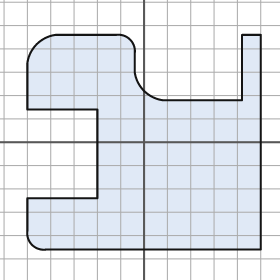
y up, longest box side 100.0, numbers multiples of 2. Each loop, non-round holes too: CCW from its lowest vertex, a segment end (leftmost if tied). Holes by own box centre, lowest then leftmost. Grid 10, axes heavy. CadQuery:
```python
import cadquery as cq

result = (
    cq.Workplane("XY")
    .moveTo(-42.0, -46.0)
    .lineTo(50.0, -46.0)
    .lineTo(50.0, 46.0)
    .lineTo(42.0, 46.0)
    .lineTo(42.0, 18.0)
    .lineTo(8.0, 18.0)
    .threePointArc((0.0, 22.0), (-4.0, 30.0))
    .lineTo(-4.0, 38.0)
    .threePointArc((-6.0, 44.0), (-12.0, 46.0))
    .lineTo(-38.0, 46.0)
    .threePointArc((-46.0, 42.0), (-50.0, 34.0))
    .lineTo(-50.0, 14.0)
    .lineTo(-20.0, 14.0)
    .lineTo(-20.0, -24.0)
    .lineTo(-50.0, -24.0)
    .lineTo(-50.0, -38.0)
    .threePointArc((-48.0, -44.0), (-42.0, -46.0))
    .close()
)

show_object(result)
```